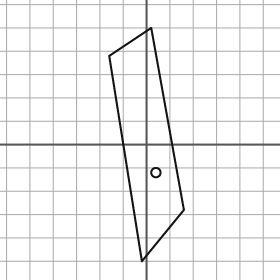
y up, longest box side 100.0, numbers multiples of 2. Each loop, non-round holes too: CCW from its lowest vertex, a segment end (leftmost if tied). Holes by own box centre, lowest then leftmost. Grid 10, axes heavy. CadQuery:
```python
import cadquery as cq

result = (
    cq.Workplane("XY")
    .moveTo(-2.0, -50.0)
    .lineTo(16.0, -28.0)
    .lineTo(2.0, 50.0)
    .lineTo(-16.0, 38.0)
    .close()
    .moveTo(4.0, -12.0)
    .circle(2.0)
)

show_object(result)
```